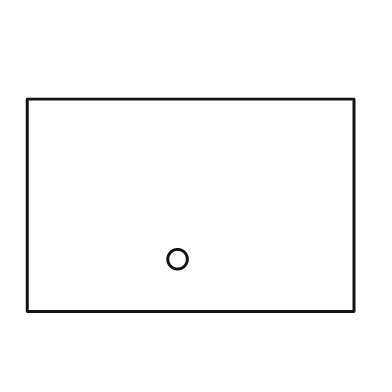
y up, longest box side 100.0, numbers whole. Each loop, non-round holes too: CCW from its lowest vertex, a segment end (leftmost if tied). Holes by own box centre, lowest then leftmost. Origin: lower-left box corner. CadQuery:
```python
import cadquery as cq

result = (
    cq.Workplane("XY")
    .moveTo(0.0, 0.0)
    .lineTo(100.0, 0.0)
    .lineTo(100.0, 65.0)
    .lineTo(0.0, 65.0)
    .close()
    .moveTo(46.0, 16.0)
    .circle(3.0)
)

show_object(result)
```